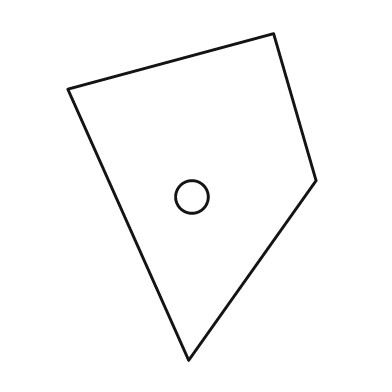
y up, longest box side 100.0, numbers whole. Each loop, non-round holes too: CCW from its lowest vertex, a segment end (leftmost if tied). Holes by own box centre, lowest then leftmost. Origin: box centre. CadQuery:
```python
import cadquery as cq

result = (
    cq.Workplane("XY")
    .moveTo(-1.0, -50.0)
    .lineTo(38.0, 5.0)
    .lineTo(25.0, 50.0)
    .lineTo(-38.0, 33.0)
    .close()
    .moveTo(0.0, 0.0)
    .circle(5.0)
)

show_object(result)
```